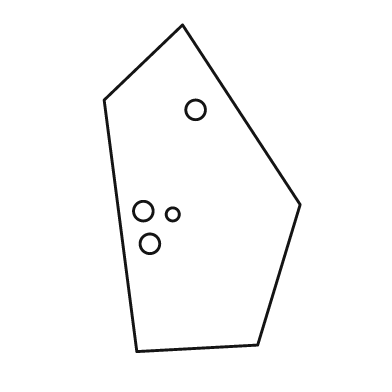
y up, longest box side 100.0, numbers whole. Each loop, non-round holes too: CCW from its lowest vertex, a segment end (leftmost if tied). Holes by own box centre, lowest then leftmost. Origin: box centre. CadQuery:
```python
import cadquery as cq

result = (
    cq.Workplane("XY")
    .moveTo(-20.0, -50.0)
    .lineTo(17.0, -48.0)
    .lineTo(30.0, -5.0)
    .lineTo(-6.0, 50.0)
    .lineTo(-30.0, 27.0)
    .close()
    .moveTo(-16.0, -17.0)
    .circle(3.0)
    .moveTo(-9.0, -8.0)
    .circle(2.0)
    .moveTo(-18.0, -7.0)
    .circle(3.0)
    .moveTo(-2.0, 24.0)
    .circle(3.0)
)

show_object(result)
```